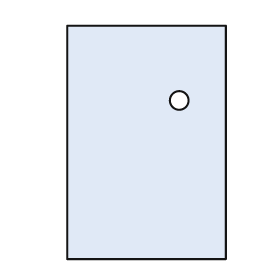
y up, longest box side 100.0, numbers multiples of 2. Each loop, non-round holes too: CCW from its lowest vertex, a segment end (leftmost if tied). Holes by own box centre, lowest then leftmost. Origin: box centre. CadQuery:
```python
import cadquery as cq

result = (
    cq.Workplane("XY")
    .moveTo(-34.0, -50.0)
    .lineTo(34.0, -50.0)
    .lineTo(34.0, 50.0)
    .lineTo(-34.0, 50.0)
    .close()
    .moveTo(14.0, 18.0)
    .circle(4.0)
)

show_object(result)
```